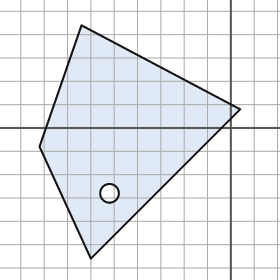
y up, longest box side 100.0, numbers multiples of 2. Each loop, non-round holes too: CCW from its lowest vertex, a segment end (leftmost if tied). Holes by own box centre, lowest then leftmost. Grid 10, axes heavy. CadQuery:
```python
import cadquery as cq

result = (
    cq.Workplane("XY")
    .moveTo(-60.0, -56.0)
    .lineTo(4.0, 8.0)
    .lineTo(-64.0, 44.0)
    .lineTo(-82.0, -8.0)
    .close()
    .moveTo(-52.0, -28.0)
    .circle(4.0)
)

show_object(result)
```